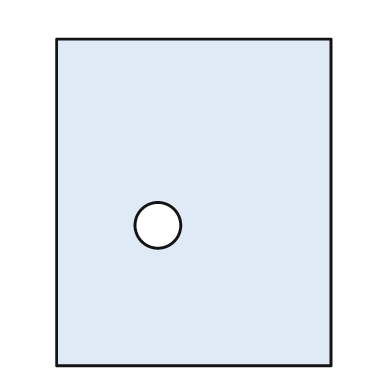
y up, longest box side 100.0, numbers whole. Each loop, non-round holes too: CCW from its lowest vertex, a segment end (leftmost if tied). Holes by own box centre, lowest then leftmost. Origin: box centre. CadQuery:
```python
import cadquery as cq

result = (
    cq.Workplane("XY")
    .moveTo(-42.0, -50.0)
    .lineTo(42.0, -50.0)
    .lineTo(42.0, 50.0)
    .lineTo(-42.0, 50.0)
    .close()
    .moveTo(-11.0, -7.0)
    .circle(7.0)
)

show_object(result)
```